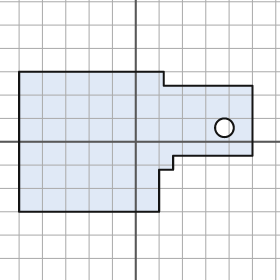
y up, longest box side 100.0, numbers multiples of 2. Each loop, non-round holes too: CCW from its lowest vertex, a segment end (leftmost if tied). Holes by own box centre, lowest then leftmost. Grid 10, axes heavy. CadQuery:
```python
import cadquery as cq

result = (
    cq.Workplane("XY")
    .moveTo(-50.0, -30.0)
    .lineTo(10.0, -30.0)
    .lineTo(10.0, -12.0)
    .lineTo(16.0, -12.0)
    .lineTo(16.0, -6.0)
    .lineTo(50.0, -6.0)
    .lineTo(50.0, 24.0)
    .lineTo(12.0, 24.0)
    .lineTo(12.0, 30.0)
    .lineTo(-50.0, 30.0)
    .close()
    .moveTo(38.0, 6.0)
    .circle(4.0)
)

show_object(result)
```